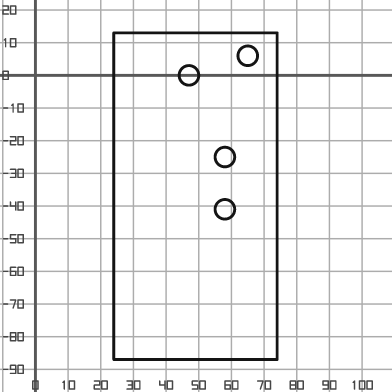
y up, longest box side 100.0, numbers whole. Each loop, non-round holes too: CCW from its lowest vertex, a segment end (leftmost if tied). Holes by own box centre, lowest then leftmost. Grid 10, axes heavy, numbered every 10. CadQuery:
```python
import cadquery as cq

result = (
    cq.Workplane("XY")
    .moveTo(24.0, -87.0)
    .lineTo(74.0, -87.0)
    .lineTo(74.0, 13.0)
    .lineTo(24.0, 13.0)
    .close()
    .moveTo(58.0, -41.0)
    .circle(3.0)
    .moveTo(58.0, -25.0)
    .circle(3.0)
    .moveTo(47.0, 0.0)
    .circle(3.0)
    .moveTo(65.0, 6.0)
    .circle(3.0)
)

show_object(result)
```